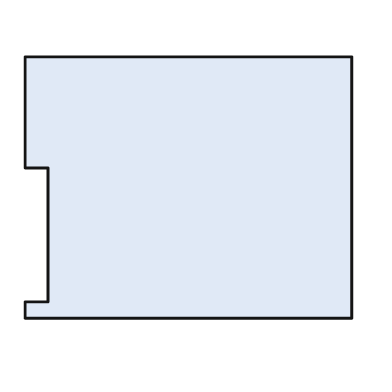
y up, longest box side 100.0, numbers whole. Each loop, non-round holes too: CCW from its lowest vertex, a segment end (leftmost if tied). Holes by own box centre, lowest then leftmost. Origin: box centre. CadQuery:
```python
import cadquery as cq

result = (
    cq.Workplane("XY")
    .moveTo(-50.0, -40.0)
    .lineTo(50.0, -40.0)
    .lineTo(50.0, 40.0)
    .lineTo(-50.0, 40.0)
    .lineTo(-50.0, 6.0)
    .lineTo(-43.0, 6.0)
    .lineTo(-43.0, -35.0)
    .lineTo(-50.0, -35.0)
    .close()
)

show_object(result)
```